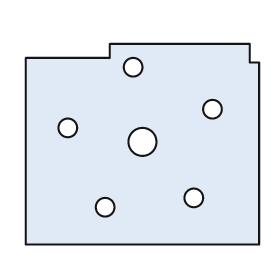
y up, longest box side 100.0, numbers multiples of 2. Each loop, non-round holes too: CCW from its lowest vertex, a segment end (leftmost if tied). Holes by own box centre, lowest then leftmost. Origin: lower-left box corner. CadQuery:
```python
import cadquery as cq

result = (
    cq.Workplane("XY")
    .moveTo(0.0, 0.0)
    .lineTo(100.0, 0.0)
    .lineTo(100.0, 78.0)
    .lineTo(96.0, 78.0)
    .lineTo(96.0, 86.0)
    .lineTo(36.0, 86.0)
    .lineTo(36.0, 80.0)
    .lineTo(0.0, 80.0)
    .close()
    .moveTo(34.0, 16.0)
    .circle(4.0)
    .moveTo(72.0, 20.0)
    .circle(4.0)
    .moveTo(50.0, 44.0)
    .circle(6.0)
    .moveTo(18.0, 50.0)
    .circle(4.0)
    .moveTo(80.0, 58.0)
    .circle(4.0)
    .moveTo(46.0, 76.0)
    .circle(4.0)
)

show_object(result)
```